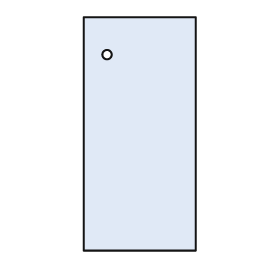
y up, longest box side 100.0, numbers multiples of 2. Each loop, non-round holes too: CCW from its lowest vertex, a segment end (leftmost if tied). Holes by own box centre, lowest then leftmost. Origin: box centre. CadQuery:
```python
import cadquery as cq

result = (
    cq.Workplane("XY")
    .moveTo(-24.0, -50.0)
    .lineTo(24.0, -50.0)
    .lineTo(24.0, 50.0)
    .lineTo(-24.0, 50.0)
    .close()
    .moveTo(-14.0, 34.0)
    .circle(2.0)
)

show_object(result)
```